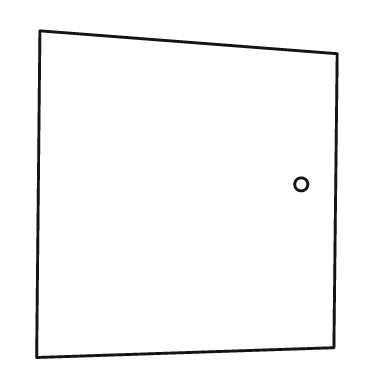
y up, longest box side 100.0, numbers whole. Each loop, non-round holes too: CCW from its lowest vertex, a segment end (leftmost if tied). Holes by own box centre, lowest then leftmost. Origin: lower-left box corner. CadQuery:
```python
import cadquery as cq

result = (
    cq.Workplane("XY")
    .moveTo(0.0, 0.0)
    .lineTo(91.0, 3.0)
    .lineTo(92.0, 93.0)
    .lineTo(1.0, 100.0)
    .close()
    .moveTo(81.0, 53.0)
    .circle(2.0)
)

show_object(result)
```